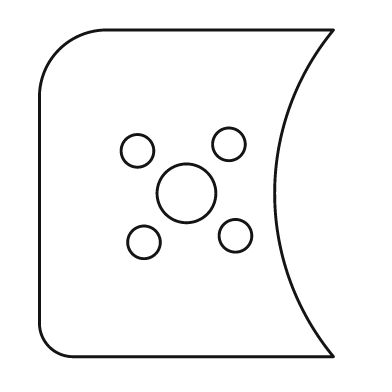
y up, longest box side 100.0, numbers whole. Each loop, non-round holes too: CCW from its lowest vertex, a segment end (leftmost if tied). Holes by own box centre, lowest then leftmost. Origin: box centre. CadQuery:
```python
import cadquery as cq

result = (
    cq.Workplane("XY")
    .moveTo(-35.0, -50.0)
    .lineTo(45.0, -50.0)
    .threePointArc((27.0, 0.0), (45.0, 50.0))
    .lineTo(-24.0, 50.0)
    .threePointArc((-39.0, 44.0), (-45.0, 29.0))
    .lineTo(-45.0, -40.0)
    .threePointArc((-42.0, -47.0), (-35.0, -50.0))
    .close()
    .moveTo(-13.0, -15.0)
    .circle(5.0)
    .moveTo(15.0, -13.0)
    .circle(5.0)
    .moveTo(0.0, 0.0)
    .circle(9.0)
    .moveTo(-15.0, 13.0)
    .circle(5.0)
    .moveTo(13.0, 15.0)
    .circle(5.0)
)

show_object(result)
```